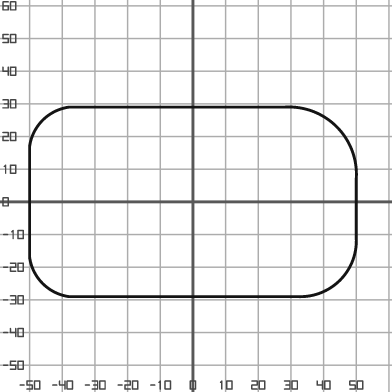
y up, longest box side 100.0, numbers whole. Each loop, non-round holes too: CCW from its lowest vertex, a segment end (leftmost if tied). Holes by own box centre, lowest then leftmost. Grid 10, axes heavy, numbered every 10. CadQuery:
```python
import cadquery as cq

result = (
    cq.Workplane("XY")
    .moveTo(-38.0, -29.0)
    .lineTo(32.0, -29.0)
    .threePointArc((45.0, -24.0), (50.0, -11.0))
    .lineTo(50.0, 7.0)
    .threePointArc((44.0, 23.0), (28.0, 29.0))
    .lineTo(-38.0, 29.0)
    .threePointArc((-46.0, 25.0), (-50.0, 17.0))
    .lineTo(-50.0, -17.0)
    .threePointArc((-46.0, -25.0), (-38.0, -29.0))
    .close()
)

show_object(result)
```